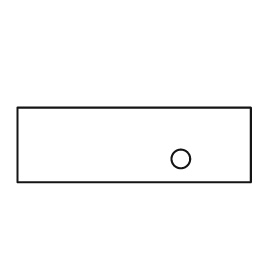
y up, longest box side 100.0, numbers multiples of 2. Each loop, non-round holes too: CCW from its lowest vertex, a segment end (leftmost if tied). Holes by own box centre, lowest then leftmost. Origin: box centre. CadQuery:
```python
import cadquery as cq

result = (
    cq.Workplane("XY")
    .moveTo(-50.0, -16.0)
    .lineTo(50.0, -16.0)
    .lineTo(50.0, 16.0)
    .lineTo(-50.0, 16.0)
    .close()
    .moveTo(20.0, -6.0)
    .circle(4.0)
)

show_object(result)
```